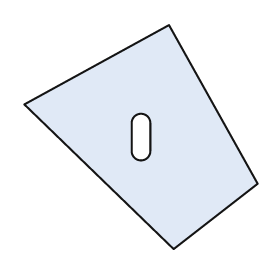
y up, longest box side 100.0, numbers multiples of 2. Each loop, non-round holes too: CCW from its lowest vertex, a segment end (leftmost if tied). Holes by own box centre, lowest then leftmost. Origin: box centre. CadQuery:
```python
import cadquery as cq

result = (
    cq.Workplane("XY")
    .moveTo(14.0, -48.0)
    .lineTo(50.0, -20.0)
    .lineTo(12.0, 48.0)
    .lineTo(-50.0, 14.0)
    .close()
    .moveTo(-4.0, -6.0)
    .threePointArc((0.0, -10.0), (4.0, -6.0))
    .lineTo(4.0, 6.0)
    .threePointArc((0.0, 10.0), (-4.0, 6.0))
    .close()
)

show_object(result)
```